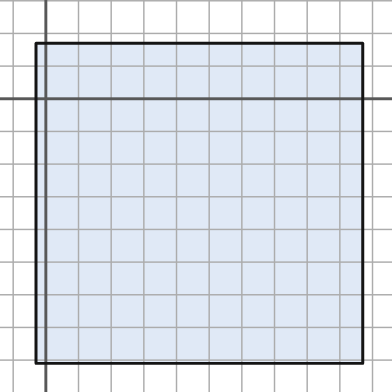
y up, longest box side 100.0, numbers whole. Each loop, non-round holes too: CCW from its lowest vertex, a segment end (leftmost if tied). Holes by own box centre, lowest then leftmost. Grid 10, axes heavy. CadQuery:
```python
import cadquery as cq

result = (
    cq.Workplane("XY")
    .moveTo(-3.0, -81.0)
    .lineTo(97.0, -81.0)
    .lineTo(97.0, 17.0)
    .lineTo(-3.0, 17.0)
    .close()
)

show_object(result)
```